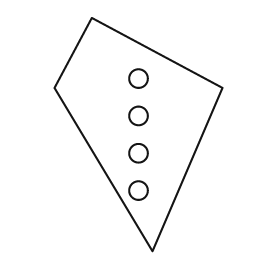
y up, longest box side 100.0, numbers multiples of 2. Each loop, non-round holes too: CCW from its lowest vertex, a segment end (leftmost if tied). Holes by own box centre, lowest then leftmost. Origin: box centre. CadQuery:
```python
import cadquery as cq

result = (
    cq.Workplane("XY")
    .moveTo(6.0, -50.0)
    .lineTo(36.0, 20.0)
    .lineTo(-20.0, 50.0)
    .lineTo(-36.0, 20.0)
    .close()
    .moveTo(0.0, -24.0)
    .circle(4.0)
    .moveTo(0.0, -8.0)
    .circle(4.0)
    .moveTo(0.0, 8.0)
    .circle(4.0)
    .moveTo(0.0, 24.0)
    .circle(4.0)
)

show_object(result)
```